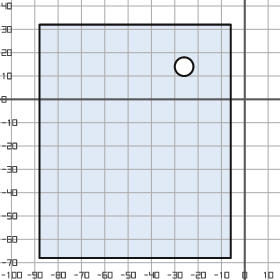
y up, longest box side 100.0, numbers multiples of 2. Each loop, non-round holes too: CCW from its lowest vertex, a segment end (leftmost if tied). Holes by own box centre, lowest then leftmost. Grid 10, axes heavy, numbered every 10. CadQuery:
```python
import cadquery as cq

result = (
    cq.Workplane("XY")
    .moveTo(-88.0, -68.0)
    .lineTo(-6.0, -68.0)
    .lineTo(-6.0, 32.0)
    .lineTo(-88.0, 32.0)
    .close()
    .moveTo(-26.0, 14.0)
    .circle(4.0)
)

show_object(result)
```